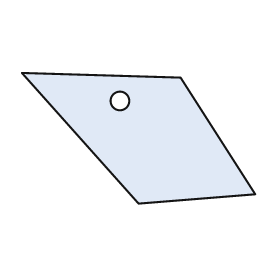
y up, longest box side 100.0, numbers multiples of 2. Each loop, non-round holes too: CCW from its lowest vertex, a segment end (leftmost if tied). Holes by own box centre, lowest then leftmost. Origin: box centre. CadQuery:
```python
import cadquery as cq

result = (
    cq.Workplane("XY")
    .moveTo(0.0, -28.0)
    .lineTo(50.0, -24.0)
    .lineTo(18.0, 26.0)
    .lineTo(-50.0, 28.0)
    .close()
    .moveTo(-8.0, 16.0)
    .circle(4.0)
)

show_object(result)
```